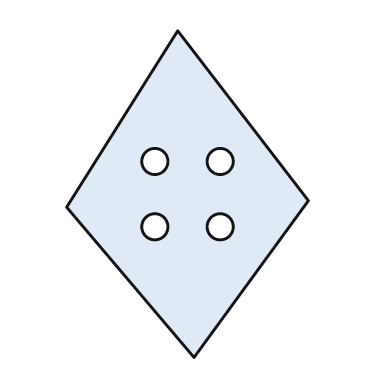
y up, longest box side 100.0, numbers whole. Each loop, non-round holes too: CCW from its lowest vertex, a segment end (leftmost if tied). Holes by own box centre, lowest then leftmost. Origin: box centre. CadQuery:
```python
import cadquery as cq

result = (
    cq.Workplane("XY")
    .moveTo(2.0, -50.0)
    .lineTo(37.0, -2.0)
    .lineTo(-3.0, 50.0)
    .lineTo(-37.0, -4.0)
    .close()
    .moveTo(-10.0, -10.0)
    .circle(4.0)
    .moveTo(10.0, -10.0)
    .circle(4.0)
    .moveTo(-10.0, 10.0)
    .circle(4.0)
    .moveTo(10.0, 10.0)
    .circle(4.0)
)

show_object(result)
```